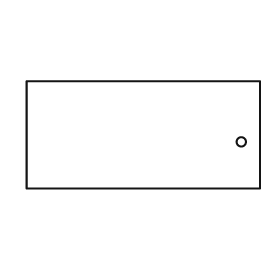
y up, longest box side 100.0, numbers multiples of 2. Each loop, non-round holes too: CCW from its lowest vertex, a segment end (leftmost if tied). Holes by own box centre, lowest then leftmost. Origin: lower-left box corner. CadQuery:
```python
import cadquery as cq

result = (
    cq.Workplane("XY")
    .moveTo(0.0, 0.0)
    .lineTo(100.0, 0.0)
    .lineTo(100.0, 46.0)
    .lineTo(0.0, 46.0)
    .close()
    .moveTo(92.0, 20.0)
    .circle(2.0)
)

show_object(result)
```